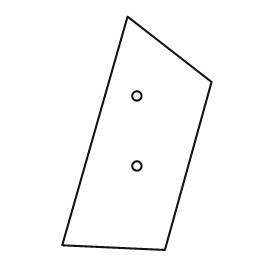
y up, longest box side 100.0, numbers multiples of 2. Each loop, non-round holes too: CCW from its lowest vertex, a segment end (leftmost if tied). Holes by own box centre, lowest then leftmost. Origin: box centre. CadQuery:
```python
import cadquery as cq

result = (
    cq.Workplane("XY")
    .moveTo(12.0, -50.0)
    .lineTo(32.0, 22.0)
    .lineTo(-4.0, 50.0)
    .lineTo(-32.0, -48.0)
    .close()
    .moveTo(0.0, -14.0)
    .circle(2.0)
    .moveTo(0.0, 16.0)
    .circle(2.0)
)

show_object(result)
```